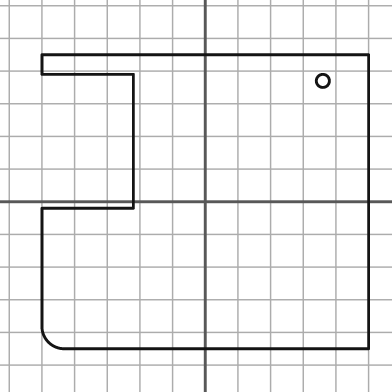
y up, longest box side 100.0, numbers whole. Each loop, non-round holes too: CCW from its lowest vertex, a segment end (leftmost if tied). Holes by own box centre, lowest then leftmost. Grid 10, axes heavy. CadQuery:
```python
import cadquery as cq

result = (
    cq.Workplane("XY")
    .moveTo(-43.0, -45.0)
    .lineTo(50.0, -45.0)
    .lineTo(50.0, 45.0)
    .lineTo(-50.0, 45.0)
    .lineTo(-50.0, 39.0)
    .lineTo(-22.0, 39.0)
    .lineTo(-22.0, -2.0)
    .lineTo(-50.0, -2.0)
    .lineTo(-50.0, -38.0)
    .threePointArc((-48.0, -43.0), (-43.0, -45.0))
    .close()
    .moveTo(36.0, 37.0)
    .circle(2.0)
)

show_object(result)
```